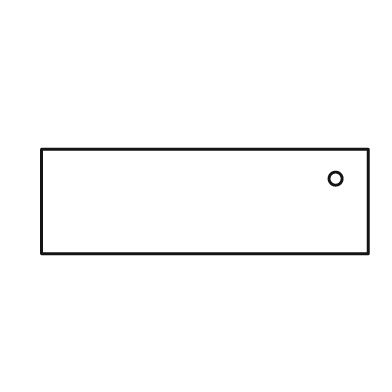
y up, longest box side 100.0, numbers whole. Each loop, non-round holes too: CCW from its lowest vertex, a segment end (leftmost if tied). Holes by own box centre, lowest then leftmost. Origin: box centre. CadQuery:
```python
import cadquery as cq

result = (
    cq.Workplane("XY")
    .moveTo(-50.0, -16.0)
    .lineTo(50.0, -16.0)
    .lineTo(50.0, 16.0)
    .lineTo(-50.0, 16.0)
    .close()
    .moveTo(40.0, 7.0)
    .circle(2.0)
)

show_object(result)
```